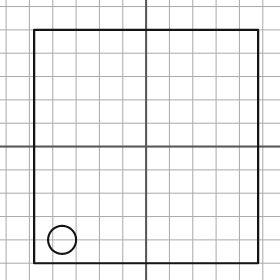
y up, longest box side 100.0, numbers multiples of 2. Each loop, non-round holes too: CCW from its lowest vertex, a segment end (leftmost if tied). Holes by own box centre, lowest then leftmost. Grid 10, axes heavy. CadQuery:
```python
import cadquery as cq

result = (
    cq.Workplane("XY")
    .moveTo(-48.0, -50.0)
    .lineTo(48.0, -50.0)
    .lineTo(48.0, 50.0)
    .lineTo(-48.0, 50.0)
    .close()
    .moveTo(-36.0, -40.0)
    .circle(6.0)
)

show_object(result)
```